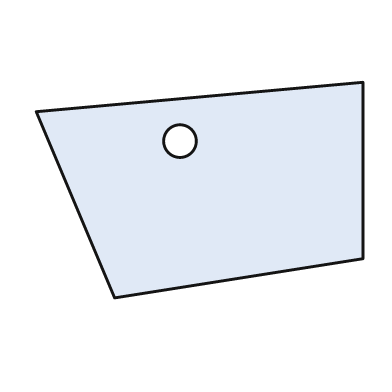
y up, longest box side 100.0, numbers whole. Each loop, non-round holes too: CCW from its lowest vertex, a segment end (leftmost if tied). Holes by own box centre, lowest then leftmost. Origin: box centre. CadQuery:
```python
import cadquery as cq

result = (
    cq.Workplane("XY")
    .moveTo(-26.0, -33.0)
    .lineTo(50.0, -21.0)
    .lineTo(50.0, 33.0)
    .lineTo(-50.0, 24.0)
    .close()
    .moveTo(-6.0, 15.0)
    .circle(5.0)
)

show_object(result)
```